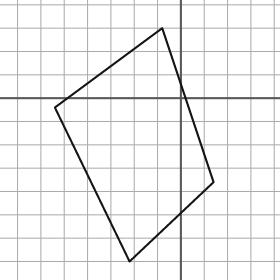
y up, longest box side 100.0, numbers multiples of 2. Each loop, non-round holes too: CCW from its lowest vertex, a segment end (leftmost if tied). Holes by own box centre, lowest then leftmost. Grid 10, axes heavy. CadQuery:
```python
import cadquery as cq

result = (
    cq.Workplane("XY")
    .moveTo(-22.0, -70.0)
    .lineTo(14.0, -36.0)
    .lineTo(-8.0, 30.0)
    .lineTo(-54.0, -4.0)
    .close()
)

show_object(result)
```